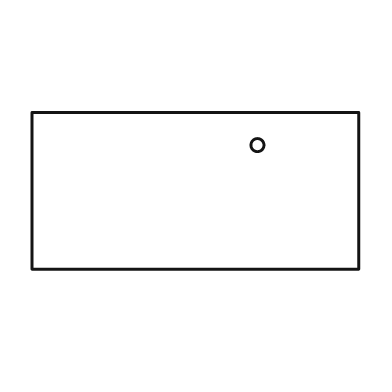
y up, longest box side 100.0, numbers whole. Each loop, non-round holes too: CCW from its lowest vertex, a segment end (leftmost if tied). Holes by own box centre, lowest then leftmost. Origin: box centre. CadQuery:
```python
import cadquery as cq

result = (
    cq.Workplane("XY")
    .moveTo(-50.0, -24.0)
    .lineTo(50.0, -24.0)
    .lineTo(50.0, 24.0)
    .lineTo(-50.0, 24.0)
    .close()
    .moveTo(19.0, 14.0)
    .circle(2.0)
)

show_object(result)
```